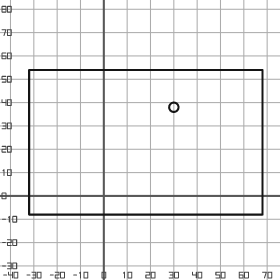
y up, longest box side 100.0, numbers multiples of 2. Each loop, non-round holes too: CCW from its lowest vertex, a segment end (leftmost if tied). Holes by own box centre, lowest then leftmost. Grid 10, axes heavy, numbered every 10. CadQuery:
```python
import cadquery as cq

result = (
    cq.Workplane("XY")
    .moveTo(-32.0, -8.0)
    .lineTo(68.0, -8.0)
    .lineTo(68.0, 54.0)
    .lineTo(-32.0, 54.0)
    .close()
    .moveTo(30.0, 38.0)
    .circle(2.0)
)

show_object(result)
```